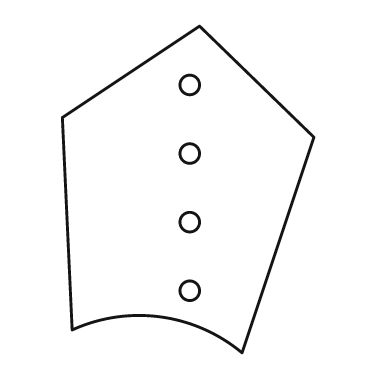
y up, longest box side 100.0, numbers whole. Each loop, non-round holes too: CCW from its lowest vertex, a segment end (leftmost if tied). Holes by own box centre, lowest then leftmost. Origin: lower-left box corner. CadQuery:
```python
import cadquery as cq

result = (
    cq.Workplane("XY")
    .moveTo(55.0, 0.0)
    .lineTo(77.0, 66.0)
    .lineTo(42.0, 100.0)
    .lineTo(0.0, 72.0)
    .lineTo(3.0, 7.0)
    .threePointArc((30.0, 11.0), (55.0, 0.0))
    .close()
    .moveTo(39.0, 19.0)
    .circle(3.0)
    .moveTo(39.0, 40.0)
    .circle(3.0)
    .moveTo(39.0, 61.0)
    .circle(3.0)
    .moveTo(39.0, 82.0)
    .circle(3.0)
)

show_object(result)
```